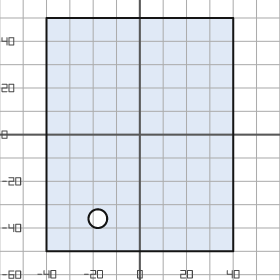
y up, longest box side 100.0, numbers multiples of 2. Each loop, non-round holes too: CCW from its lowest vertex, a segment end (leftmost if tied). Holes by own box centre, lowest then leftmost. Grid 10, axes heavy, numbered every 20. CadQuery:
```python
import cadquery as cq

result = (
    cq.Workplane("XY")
    .moveTo(-40.0, -50.0)
    .lineTo(40.0, -50.0)
    .lineTo(40.0, 50.0)
    .lineTo(-40.0, 50.0)
    .close()
    .moveTo(-18.0, -36.0)
    .circle(4.0)
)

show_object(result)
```